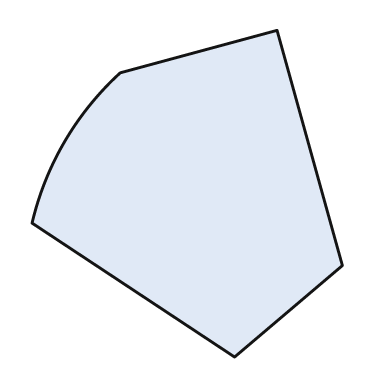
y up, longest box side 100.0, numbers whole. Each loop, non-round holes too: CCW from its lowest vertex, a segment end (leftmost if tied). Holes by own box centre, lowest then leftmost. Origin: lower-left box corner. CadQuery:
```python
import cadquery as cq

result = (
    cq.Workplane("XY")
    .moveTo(62.0, 0.0)
    .lineTo(95.0, 28.0)
    .lineTo(75.0, 100.0)
    .lineTo(27.0, 87.0)
    .threePointArc((10.0, 66.0), (0.0, 41.0))
    .close()
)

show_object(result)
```